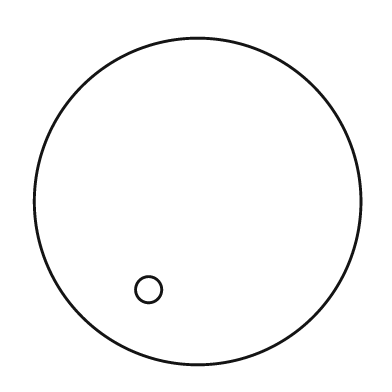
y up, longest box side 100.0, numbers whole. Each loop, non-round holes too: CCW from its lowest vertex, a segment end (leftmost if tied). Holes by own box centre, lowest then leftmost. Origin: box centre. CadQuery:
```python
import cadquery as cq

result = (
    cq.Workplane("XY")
    .moveTo(0.0, 0.0)
    .circle(50.0)
    .moveTo(-15.0, -27.0)
    .circle(4.0)
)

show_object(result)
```